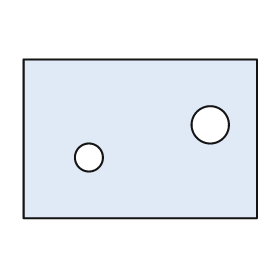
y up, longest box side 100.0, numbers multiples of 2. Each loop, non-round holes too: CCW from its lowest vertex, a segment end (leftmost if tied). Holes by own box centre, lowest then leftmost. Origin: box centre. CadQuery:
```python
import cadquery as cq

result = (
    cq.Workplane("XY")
    .moveTo(-50.0, -34.0)
    .lineTo(50.0, -34.0)
    .lineTo(50.0, 34.0)
    .lineTo(-50.0, 34.0)
    .close()
    .moveTo(-22.0, -8.0)
    .circle(6.0)
    .moveTo(30.0, 6.0)
    .circle(8.0)
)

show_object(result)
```